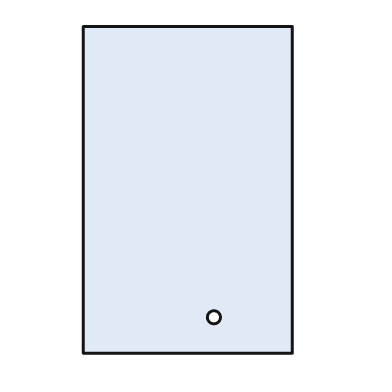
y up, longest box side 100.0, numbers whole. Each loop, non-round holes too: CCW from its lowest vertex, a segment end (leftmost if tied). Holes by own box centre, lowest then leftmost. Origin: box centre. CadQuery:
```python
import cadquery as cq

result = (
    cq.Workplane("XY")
    .moveTo(-32.0, -50.0)
    .lineTo(32.0, -50.0)
    .lineTo(32.0, 50.0)
    .lineTo(-32.0, 50.0)
    .close()
    .moveTo(8.0, -39.0)
    .circle(2.0)
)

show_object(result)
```